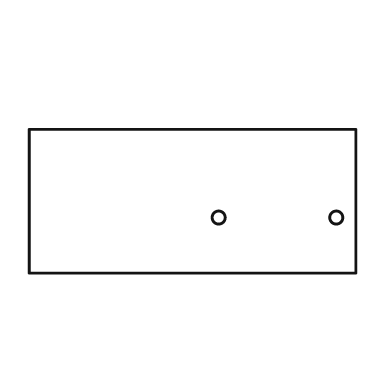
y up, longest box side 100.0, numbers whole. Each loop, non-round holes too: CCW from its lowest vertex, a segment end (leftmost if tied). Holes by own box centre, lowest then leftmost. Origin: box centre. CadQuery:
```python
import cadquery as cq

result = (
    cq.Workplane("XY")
    .moveTo(-50.0, -22.0)
    .lineTo(50.0, -22.0)
    .lineTo(50.0, 22.0)
    .lineTo(-50.0, 22.0)
    .close()
    .moveTo(8.0, -5.0)
    .circle(2.0)
    .moveTo(44.0, -5.0)
    .circle(2.0)
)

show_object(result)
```